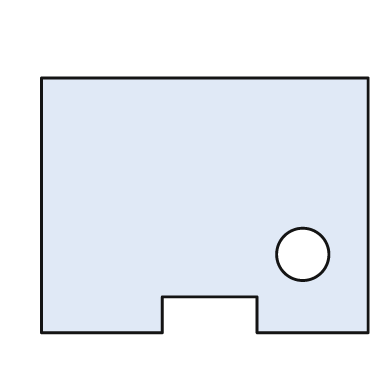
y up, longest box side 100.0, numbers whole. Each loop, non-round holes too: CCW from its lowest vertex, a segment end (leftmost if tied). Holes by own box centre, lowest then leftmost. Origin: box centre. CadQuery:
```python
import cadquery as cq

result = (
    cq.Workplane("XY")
    .moveTo(-50.0, -39.0)
    .lineTo(-13.0, -39.0)
    .lineTo(-13.0, -28.0)
    .lineTo(16.0, -28.0)
    .lineTo(16.0, -39.0)
    .lineTo(50.0, -39.0)
    .lineTo(50.0, 39.0)
    .lineTo(-50.0, 39.0)
    .close()
    .moveTo(30.0, -15.0)
    .circle(8.0)
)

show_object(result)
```